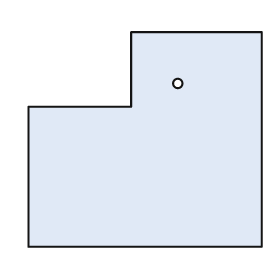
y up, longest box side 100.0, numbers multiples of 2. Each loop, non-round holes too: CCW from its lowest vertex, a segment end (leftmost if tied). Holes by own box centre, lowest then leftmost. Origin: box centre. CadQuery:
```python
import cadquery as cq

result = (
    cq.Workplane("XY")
    .moveTo(-50.0, -46.0)
    .lineTo(50.0, -46.0)
    .lineTo(50.0, 46.0)
    .lineTo(-6.0, 46.0)
    .lineTo(-6.0, 14.0)
    .lineTo(-50.0, 14.0)
    .close()
    .moveTo(14.0, 24.0)
    .circle(2.0)
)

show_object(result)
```